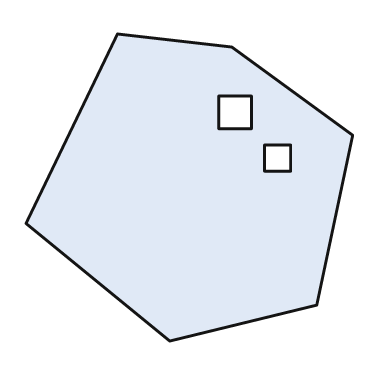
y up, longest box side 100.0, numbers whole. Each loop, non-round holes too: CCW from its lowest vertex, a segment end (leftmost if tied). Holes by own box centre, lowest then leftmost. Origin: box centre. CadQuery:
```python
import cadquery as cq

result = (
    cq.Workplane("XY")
    .moveTo(-6.0, -47.0)
    .lineTo(39.0, -36.0)
    .lineTo(50.0, 16.0)
    .lineTo(13.0, 43.0)
    .lineTo(-22.0, 47.0)
    .lineTo(-50.0, -11.0)
    .close()
    .moveTo(23.0, 5.0)
    .lineTo(31.0, 5.0)
    .lineTo(31.0, 13.0)
    .lineTo(23.0, 13.0)
    .close()
    .moveTo(9.0, 18.0)
    .lineTo(19.0, 18.0)
    .lineTo(19.0, 28.0)
    .lineTo(9.0, 28.0)
    .close()
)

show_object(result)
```